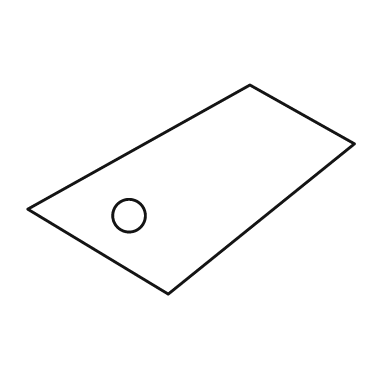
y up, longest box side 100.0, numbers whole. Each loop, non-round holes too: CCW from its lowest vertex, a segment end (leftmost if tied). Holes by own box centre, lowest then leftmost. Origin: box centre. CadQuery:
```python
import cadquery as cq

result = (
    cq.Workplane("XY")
    .moveTo(-7.0, -32.0)
    .lineTo(50.0, 14.0)
    .lineTo(18.0, 32.0)
    .lineTo(-50.0, -6.0)
    .close()
    .moveTo(-19.0, -8.0)
    .circle(5.0)
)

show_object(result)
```